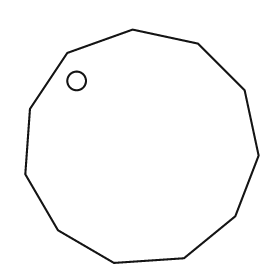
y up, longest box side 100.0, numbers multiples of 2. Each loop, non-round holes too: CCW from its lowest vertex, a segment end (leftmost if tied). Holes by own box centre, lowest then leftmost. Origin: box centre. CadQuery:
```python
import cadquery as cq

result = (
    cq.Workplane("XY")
    .moveTo(-12.0, -50.0)
    .lineTo(18.0, -48.0)
    .lineTo(40.0, -30.0)
    .lineTo(50.0, -4.0)
    .lineTo(44.0, 24.0)
    .lineTo(24.0, 44.0)
    .lineTo(-4.0, 50.0)
    .lineTo(-32.0, 40.0)
    .lineTo(-48.0, 16.0)
    .lineTo(-50.0, -12.0)
    .lineTo(-36.0, -36.0)
    .close()
    .moveTo(-28.0, 28.0)
    .circle(4.0)
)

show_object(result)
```